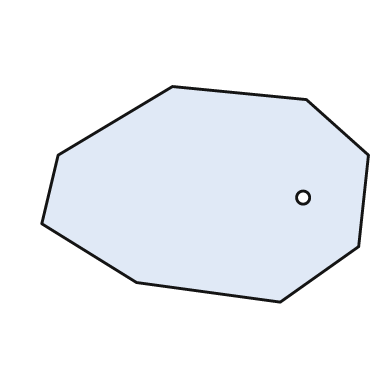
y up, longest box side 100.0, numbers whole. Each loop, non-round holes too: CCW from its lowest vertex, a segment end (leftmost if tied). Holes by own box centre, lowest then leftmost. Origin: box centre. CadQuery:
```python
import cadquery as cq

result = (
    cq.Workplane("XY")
    .moveTo(23.0, -33.0)
    .lineTo(47.0, -16.0)
    .lineTo(50.0, 12.0)
    .lineTo(31.0, 29.0)
    .lineTo(-10.0, 33.0)
    .lineTo(-45.0, 12.0)
    .lineTo(-50.0, -9.0)
    .lineTo(-21.0, -27.0)
    .close()
    .moveTo(30.0, -1.0)
    .circle(2.0)
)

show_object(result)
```